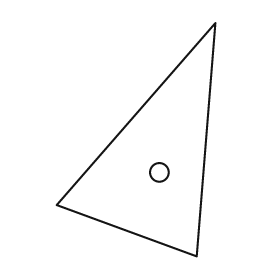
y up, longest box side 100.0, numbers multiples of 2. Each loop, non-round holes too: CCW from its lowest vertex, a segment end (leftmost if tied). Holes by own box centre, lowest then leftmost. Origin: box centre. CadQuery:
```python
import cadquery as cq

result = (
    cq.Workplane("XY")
    .moveTo(26.0, -50.0)
    .lineTo(34.0, 50.0)
    .lineTo(-34.0, -28.0)
    .close()
    .moveTo(10.0, -14.0)
    .circle(4.0)
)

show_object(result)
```